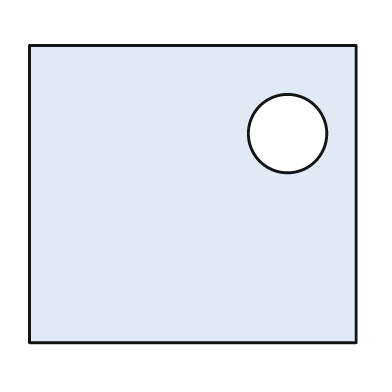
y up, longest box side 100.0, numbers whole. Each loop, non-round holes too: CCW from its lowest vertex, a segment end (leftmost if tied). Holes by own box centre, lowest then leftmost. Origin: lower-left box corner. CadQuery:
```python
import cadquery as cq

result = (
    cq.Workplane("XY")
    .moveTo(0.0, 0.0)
    .lineTo(100.0, 0.0)
    .lineTo(100.0, 91.0)
    .lineTo(0.0, 91.0)
    .close()
    .moveTo(79.0, 64.0)
    .circle(12.0)
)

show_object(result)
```